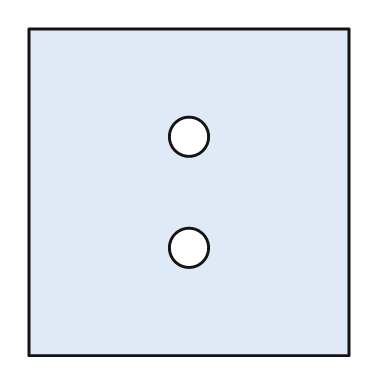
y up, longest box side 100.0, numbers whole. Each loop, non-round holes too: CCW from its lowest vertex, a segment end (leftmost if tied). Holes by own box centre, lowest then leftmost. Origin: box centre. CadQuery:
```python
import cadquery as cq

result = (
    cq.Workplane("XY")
    .moveTo(-49.0, -50.0)
    .lineTo(49.0, -50.0)
    .lineTo(49.0, 50.0)
    .lineTo(-49.0, 50.0)
    .close()
    .moveTo(0.0, -17.0)
    .circle(6.0)
    .moveTo(0.0, 17.0)
    .circle(6.0)
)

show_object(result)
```